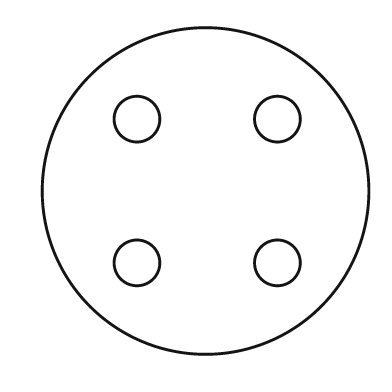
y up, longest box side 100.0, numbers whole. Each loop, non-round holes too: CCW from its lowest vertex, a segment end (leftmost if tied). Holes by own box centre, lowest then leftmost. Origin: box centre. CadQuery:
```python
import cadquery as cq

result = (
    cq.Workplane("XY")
    .moveTo(0.0, 0.0)
    .circle(50.0)
    .moveTo(-21.0, -22.0)
    .circle(7.0)
    .moveTo(22.0, -22.0)
    .circle(7.0)
    .moveTo(-21.0, 22.0)
    .circle(7.0)
    .moveTo(22.0, 22.0)
    .circle(7.0)
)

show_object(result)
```